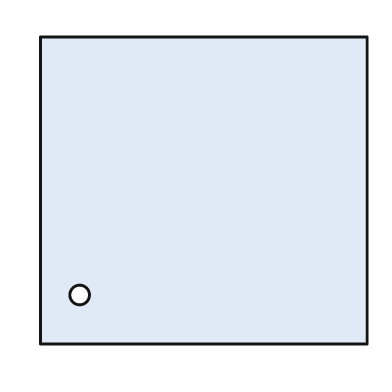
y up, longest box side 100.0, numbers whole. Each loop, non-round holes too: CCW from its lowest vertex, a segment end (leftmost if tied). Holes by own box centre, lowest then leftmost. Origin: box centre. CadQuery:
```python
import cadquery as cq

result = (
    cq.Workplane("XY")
    .moveTo(-50.0, -47.0)
    .lineTo(50.0, -47.0)
    .lineTo(50.0, 47.0)
    .lineTo(-50.0, 47.0)
    .close()
    .moveTo(-38.0, -32.0)
    .circle(3.0)
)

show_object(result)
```